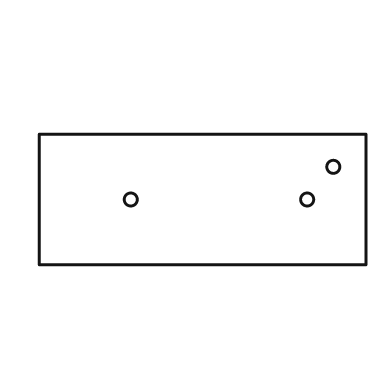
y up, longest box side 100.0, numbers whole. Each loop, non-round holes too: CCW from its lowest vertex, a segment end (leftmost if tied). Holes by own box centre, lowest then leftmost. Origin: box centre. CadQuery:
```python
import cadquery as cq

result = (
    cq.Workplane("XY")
    .moveTo(-50.0, -20.0)
    .lineTo(50.0, -20.0)
    .lineTo(50.0, 20.0)
    .lineTo(-50.0, 20.0)
    .close()
    .moveTo(-22.0, 0.0)
    .circle(2.0)
    .moveTo(32.0, 0.0)
    .circle(2.0)
    .moveTo(40.0, 10.0)
    .circle(2.0)
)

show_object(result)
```